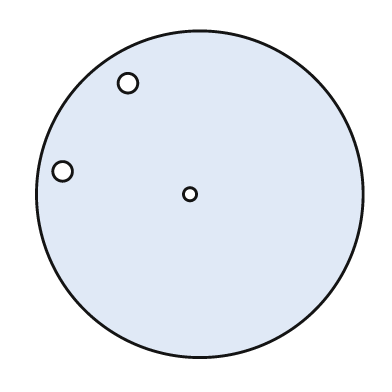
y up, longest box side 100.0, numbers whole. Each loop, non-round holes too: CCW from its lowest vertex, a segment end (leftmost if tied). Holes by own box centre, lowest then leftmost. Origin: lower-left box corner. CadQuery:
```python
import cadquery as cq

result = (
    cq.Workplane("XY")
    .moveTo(50.0, 50.0)
    .circle(50.0)
    .moveTo(47.0, 50.0)
    .circle(2.0)
    .moveTo(8.0, 57.0)
    .circle(3.0)
    .moveTo(28.0, 84.0)
    .circle(3.0)
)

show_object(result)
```